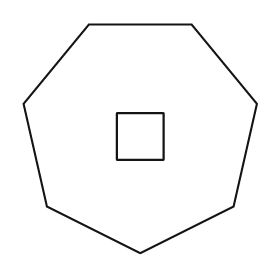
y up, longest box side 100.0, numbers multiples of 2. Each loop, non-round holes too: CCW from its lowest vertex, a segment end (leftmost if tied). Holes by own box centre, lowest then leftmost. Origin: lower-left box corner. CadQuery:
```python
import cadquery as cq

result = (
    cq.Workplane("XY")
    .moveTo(50.0, 0.0)
    .lineTo(90.0, 20.0)
    .lineTo(100.0, 64.0)
    .lineTo(72.0, 98.0)
    .lineTo(28.0, 98.0)
    .lineTo(0.0, 64.0)
    .lineTo(10.0, 20.0)
    .close()
    .moveTo(40.0, 40.0)
    .lineTo(60.0, 40.0)
    .lineTo(60.0, 60.0)
    .lineTo(40.0, 60.0)
    .close()
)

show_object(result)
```